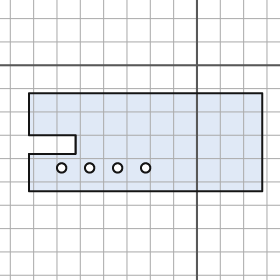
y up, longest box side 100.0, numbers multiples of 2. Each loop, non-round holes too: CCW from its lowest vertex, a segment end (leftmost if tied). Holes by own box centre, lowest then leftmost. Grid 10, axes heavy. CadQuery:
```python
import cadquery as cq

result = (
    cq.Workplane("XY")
    .moveTo(-72.0, -54.0)
    .lineTo(28.0, -54.0)
    .lineTo(28.0, -12.0)
    .lineTo(-72.0, -12.0)
    .lineTo(-72.0, -30.0)
    .lineTo(-52.0, -30.0)
    .lineTo(-52.0, -38.0)
    .lineTo(-72.0, -38.0)
    .close()
    .moveTo(-58.0, -44.0)
    .circle(2.0)
    .moveTo(-46.0, -44.0)
    .circle(2.0)
    .moveTo(-34.0, -44.0)
    .circle(2.0)
    .moveTo(-22.0, -44.0)
    .circle(2.0)
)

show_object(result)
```